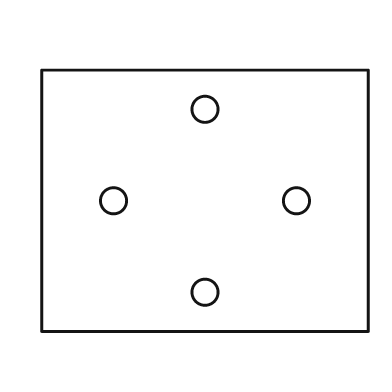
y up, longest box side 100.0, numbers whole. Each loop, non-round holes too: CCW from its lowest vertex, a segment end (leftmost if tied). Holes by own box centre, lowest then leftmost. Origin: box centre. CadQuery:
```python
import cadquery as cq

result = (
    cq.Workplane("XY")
    .moveTo(-50.0, -40.0)
    .lineTo(50.0, -40.0)
    .lineTo(50.0, 40.0)
    .lineTo(-50.0, 40.0)
    .close()
    .moveTo(0.0, -28.0)
    .circle(4.0)
    .moveTo(-28.0, 0.0)
    .circle(4.0)
    .moveTo(28.0, 0.0)
    .circle(4.0)
    .moveTo(0.0, 28.0)
    .circle(4.0)
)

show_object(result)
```